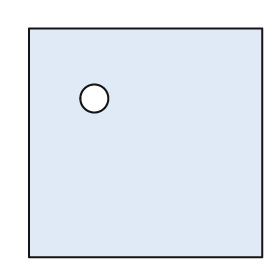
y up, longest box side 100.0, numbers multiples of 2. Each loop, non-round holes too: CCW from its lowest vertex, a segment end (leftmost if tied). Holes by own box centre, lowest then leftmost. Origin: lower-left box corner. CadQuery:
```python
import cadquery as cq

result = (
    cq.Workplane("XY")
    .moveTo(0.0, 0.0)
    .lineTo(100.0, 0.0)
    .lineTo(100.0, 98.0)
    .lineTo(0.0, 98.0)
    .close()
    .moveTo(28.0, 68.0)
    .circle(6.0)
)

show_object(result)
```